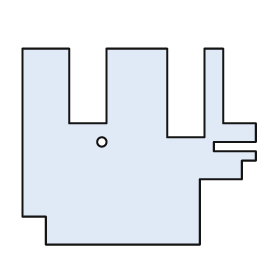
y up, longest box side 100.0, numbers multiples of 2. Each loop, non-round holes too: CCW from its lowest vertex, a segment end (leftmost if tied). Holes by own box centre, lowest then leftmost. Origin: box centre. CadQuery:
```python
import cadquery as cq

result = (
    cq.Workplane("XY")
    .moveTo(-40.0, -42.0)
    .lineTo(26.0, -42.0)
    .lineTo(26.0, -14.0)
    .lineTo(44.0, -14.0)
    .lineTo(44.0, -6.0)
    .lineTo(50.0, -6.0)
    .lineTo(50.0, -2.0)
    .lineTo(32.0, -2.0)
    .lineTo(32.0, 2.0)
    .lineTo(50.0, 2.0)
    .lineTo(50.0, 10.0)
    .lineTo(36.0, 10.0)
    .lineTo(36.0, 42.0)
    .lineTo(28.0, 42.0)
    .lineTo(28.0, 4.0)
    .lineTo(12.0, 4.0)
    .lineTo(12.0, 42.0)
    .lineTo(-14.0, 42.0)
    .lineTo(-14.0, 10.0)
    .lineTo(-30.0, 10.0)
    .lineTo(-30.0, 42.0)
    .lineTo(-50.0, 42.0)
    .lineTo(-50.0, -30.0)
    .lineTo(-40.0, -30.0)
    .close()
    .moveTo(-16.0, 2.0)
    .circle(2.0)
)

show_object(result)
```